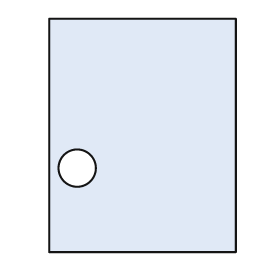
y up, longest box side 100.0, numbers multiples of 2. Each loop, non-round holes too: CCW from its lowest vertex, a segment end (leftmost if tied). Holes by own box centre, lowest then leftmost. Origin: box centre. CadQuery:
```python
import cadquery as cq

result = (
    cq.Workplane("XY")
    .moveTo(-40.0, -50.0)
    .lineTo(40.0, -50.0)
    .lineTo(40.0, 50.0)
    .lineTo(-40.0, 50.0)
    .close()
    .moveTo(-28.0, -14.0)
    .circle(8.0)
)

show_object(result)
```